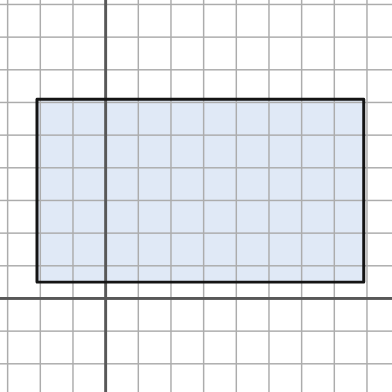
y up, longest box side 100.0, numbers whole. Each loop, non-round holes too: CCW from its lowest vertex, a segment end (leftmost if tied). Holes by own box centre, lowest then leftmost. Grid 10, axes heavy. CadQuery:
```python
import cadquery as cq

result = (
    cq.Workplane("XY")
    .moveTo(-21.0, 5.0)
    .lineTo(79.0, 5.0)
    .lineTo(79.0, 61.0)
    .lineTo(-21.0, 61.0)
    .close()
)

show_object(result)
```